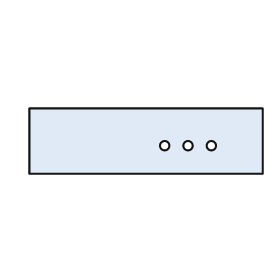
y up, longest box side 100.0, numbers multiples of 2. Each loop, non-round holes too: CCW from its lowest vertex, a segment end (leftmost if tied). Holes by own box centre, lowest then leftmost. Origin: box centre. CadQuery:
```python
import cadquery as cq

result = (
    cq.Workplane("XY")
    .moveTo(-50.0, -14.0)
    .lineTo(50.0, -14.0)
    .lineTo(50.0, 14.0)
    .lineTo(-50.0, 14.0)
    .close()
    .moveTo(8.0, -2.0)
    .circle(2.0)
    .moveTo(18.0, -2.0)
    .circle(2.0)
    .moveTo(28.0, -2.0)
    .circle(2.0)
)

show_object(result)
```